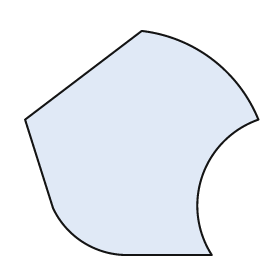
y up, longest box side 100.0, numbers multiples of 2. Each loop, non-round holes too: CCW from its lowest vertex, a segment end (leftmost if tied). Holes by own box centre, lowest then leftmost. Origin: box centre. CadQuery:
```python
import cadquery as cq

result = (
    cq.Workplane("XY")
    .moveTo(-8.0, -48.0)
    .lineTo(30.0, -48.0)
    .threePointArc((26.0, -14.0), (50.0, 10.0))
    .threePointArc((30.0, 36.0), (0.0, 48.0))
    .lineTo(-50.0, 10.0)
    .lineTo(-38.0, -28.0)
    .threePointArc((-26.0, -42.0), (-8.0, -48.0))
    .close()
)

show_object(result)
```